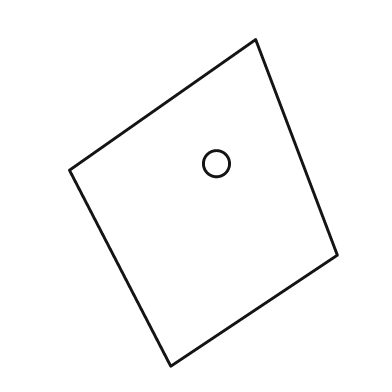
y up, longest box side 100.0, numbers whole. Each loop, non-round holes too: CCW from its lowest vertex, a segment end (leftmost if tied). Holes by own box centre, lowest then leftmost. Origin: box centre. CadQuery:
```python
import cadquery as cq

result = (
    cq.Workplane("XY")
    .moveTo(-10.0, -50.0)
    .lineTo(41.0, -16.0)
    .lineTo(16.0, 50.0)
    .lineTo(-41.0, 10.0)
    .close()
    .moveTo(4.0, 12.0)
    .circle(4.0)
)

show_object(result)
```